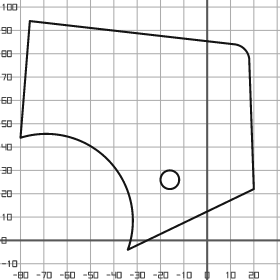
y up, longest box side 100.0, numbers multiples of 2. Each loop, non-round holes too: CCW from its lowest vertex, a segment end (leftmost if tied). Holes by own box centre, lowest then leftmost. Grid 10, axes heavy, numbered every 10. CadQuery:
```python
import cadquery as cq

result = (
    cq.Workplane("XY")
    .moveTo(-34.0, -4.0)
    .lineTo(20.0, 22.0)
    .lineTo(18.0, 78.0)
    .threePointArc((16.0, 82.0), (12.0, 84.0))
    .lineTo(-76.0, 94.0)
    .lineTo(-80.0, 44.0)
    .threePointArc((-42.0, 34.0), (-34.0, -4.0))
    .close()
    .moveTo(-16.0, 26.0)
    .circle(4.0)
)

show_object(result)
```